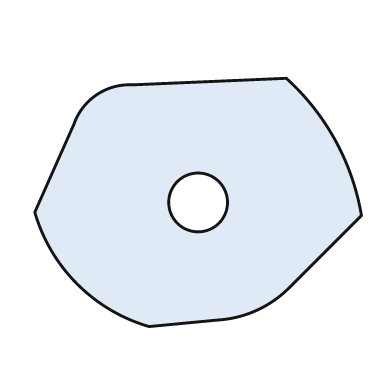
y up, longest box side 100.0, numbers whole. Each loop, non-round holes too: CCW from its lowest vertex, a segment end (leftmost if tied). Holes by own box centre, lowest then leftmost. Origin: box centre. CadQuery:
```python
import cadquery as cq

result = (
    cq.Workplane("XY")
    .moveTo(-15.0, -38.0)
    .lineTo(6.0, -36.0)
    .threePointArc((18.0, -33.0), (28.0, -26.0))
    .lineTo(50.0, -4.0)
    .threePointArc((42.0, 19.0), (27.0, 38.0))
    .lineTo(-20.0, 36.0)
    .threePointArc((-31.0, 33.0), (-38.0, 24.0))
    .lineTo(-50.0, -3.0)
    .threePointArc((-37.0, -25.0), (-15.0, -38.0))
    .close()
    .moveTo(0.0, 0.0)
    .circle(9.0)
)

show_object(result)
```